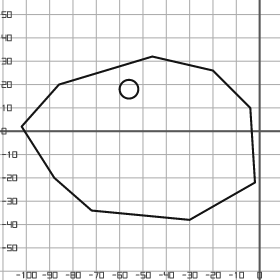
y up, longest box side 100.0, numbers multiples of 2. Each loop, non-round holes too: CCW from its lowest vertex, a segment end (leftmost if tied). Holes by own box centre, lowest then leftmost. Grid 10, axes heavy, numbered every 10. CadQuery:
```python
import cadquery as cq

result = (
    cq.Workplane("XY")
    .moveTo(-30.0, -38.0)
    .lineTo(-2.0, -22.0)
    .lineTo(-4.0, 10.0)
    .lineTo(-20.0, 26.0)
    .lineTo(-46.0, 32.0)
    .lineTo(-86.0, 20.0)
    .lineTo(-102.0, 2.0)
    .lineTo(-88.0, -20.0)
    .lineTo(-72.0, -34.0)
    .close()
    .moveTo(-56.0, 18.0)
    .circle(4.0)
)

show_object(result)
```